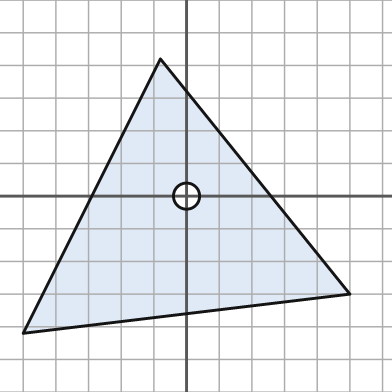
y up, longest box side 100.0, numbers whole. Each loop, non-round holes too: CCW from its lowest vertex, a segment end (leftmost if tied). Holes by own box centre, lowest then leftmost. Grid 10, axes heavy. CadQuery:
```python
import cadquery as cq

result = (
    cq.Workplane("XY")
    .moveTo(-50.0, -42.0)
    .lineTo(50.0, -30.0)
    .lineTo(-8.0, 42.0)
    .close()
    .moveTo(0.0, 0.0)
    .circle(4.0)
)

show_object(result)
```